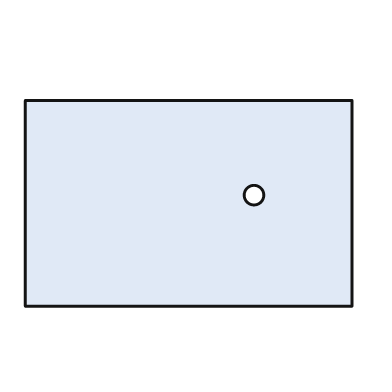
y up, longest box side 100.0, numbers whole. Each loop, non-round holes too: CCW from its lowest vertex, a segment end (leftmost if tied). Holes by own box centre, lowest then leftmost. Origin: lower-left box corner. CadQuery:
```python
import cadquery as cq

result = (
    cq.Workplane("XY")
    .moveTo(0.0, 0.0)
    .lineTo(100.0, 0.0)
    .lineTo(100.0, 63.0)
    .lineTo(0.0, 63.0)
    .close()
    .moveTo(70.0, 34.0)
    .circle(3.0)
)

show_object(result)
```